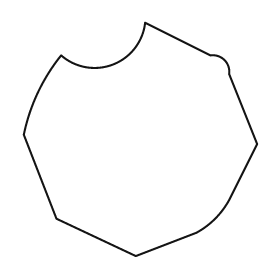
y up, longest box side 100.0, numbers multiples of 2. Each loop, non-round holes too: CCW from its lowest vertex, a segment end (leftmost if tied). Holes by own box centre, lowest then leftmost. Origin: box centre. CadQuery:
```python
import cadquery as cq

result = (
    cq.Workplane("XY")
    .moveTo(-2.0, -50.0)
    .lineTo(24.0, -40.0)
    .threePointArc((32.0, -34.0), (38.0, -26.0))
    .lineTo(50.0, -2.0)
    .lineTo(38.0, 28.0)
    .threePointArc((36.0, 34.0), (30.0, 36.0))
    .lineTo(2.0, 50.0)
    .threePointArc((-12.0, 32.0), (-34.0, 36.0))
    .threePointArc((-44.0, 20.0), (-50.0, 2.0))
    .lineTo(-36.0, -34.0)
    .close()
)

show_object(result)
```